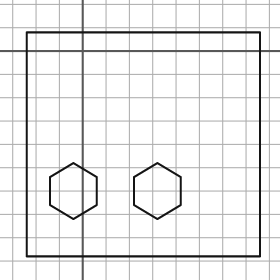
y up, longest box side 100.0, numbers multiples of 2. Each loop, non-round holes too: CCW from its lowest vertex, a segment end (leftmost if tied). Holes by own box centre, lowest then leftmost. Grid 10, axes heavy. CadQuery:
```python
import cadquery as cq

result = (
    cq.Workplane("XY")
    .moveTo(-24.0, -88.0)
    .lineTo(76.0, -88.0)
    .lineTo(76.0, 8.0)
    .lineTo(-24.0, 8.0)
    .close()
    .moveTo(-4.0, -72.0)
    .lineTo(6.0, -66.0)
    .lineTo(6.0, -54.0)
    .lineTo(-4.0, -48.0)
    .lineTo(-14.0, -54.0)
    .lineTo(-14.0, -66.0)
    .close()
    .moveTo(32.0, -72.0)
    .lineTo(42.0, -66.0)
    .lineTo(42.0, -54.0)
    .lineTo(32.0, -48.0)
    .lineTo(22.0, -54.0)
    .lineTo(22.0, -66.0)
    .close()
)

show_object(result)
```